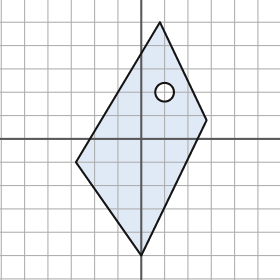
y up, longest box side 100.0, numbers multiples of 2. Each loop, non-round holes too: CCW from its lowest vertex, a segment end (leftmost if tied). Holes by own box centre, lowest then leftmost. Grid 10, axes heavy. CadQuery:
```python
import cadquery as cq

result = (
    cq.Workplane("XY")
    .moveTo(0.0, -50.0)
    .lineTo(28.0, 8.0)
    .lineTo(8.0, 50.0)
    .lineTo(-28.0, -10.0)
    .close()
    .moveTo(10.0, 20.0)
    .circle(4.0)
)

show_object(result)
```